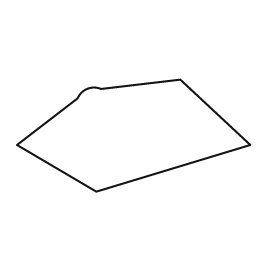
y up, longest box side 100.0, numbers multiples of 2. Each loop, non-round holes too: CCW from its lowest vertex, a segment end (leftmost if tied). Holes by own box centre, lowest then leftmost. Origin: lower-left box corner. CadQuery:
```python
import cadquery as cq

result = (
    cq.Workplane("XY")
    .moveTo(34.0, 0.0)
    .lineTo(100.0, 20.0)
    .lineTo(70.0, 48.0)
    .lineTo(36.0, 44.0)
    .threePointArc((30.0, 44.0), (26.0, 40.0))
    .lineTo(0.0, 20.0)
    .close()
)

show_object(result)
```